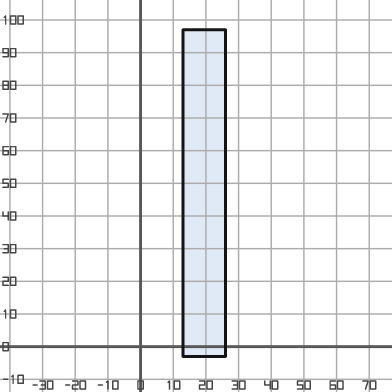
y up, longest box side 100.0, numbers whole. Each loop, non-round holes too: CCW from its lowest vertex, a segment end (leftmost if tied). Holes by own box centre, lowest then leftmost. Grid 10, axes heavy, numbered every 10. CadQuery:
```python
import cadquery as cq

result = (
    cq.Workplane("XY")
    .moveTo(13.0, -3.0)
    .lineTo(26.0, -3.0)
    .lineTo(26.0, 97.0)
    .lineTo(13.0, 97.0)
    .close()
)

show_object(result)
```